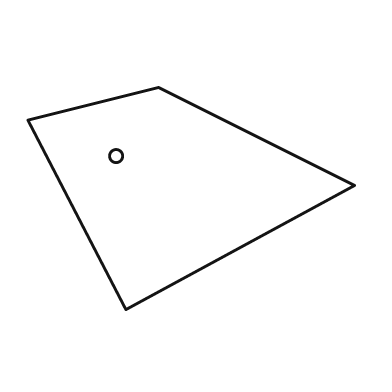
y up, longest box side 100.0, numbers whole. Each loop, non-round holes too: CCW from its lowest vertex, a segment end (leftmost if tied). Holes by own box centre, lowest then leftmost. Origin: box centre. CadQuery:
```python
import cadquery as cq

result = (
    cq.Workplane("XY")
    .moveTo(-20.0, -34.0)
    .lineTo(50.0, 4.0)
    .lineTo(-10.0, 34.0)
    .lineTo(-50.0, 24.0)
    .close()
    .moveTo(-23.0, 13.0)
    .circle(2.0)
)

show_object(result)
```